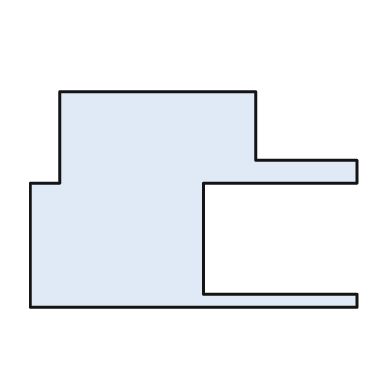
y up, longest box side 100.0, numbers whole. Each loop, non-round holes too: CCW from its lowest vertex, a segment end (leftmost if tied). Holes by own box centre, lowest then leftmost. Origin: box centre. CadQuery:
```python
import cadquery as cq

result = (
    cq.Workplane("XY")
    .moveTo(-50.0, -33.0)
    .lineTo(50.0, -33.0)
    .lineTo(50.0, -29.0)
    .lineTo(3.0, -29.0)
    .lineTo(3.0, 5.0)
    .lineTo(50.0, 5.0)
    .lineTo(50.0, 12.0)
    .lineTo(19.0, 12.0)
    .lineTo(19.0, 33.0)
    .lineTo(-41.0, 33.0)
    .lineTo(-41.0, 5.0)
    .lineTo(-50.0, 5.0)
    .close()
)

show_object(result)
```